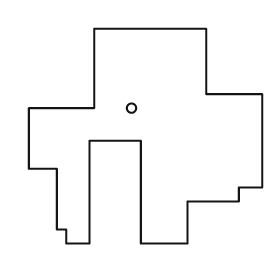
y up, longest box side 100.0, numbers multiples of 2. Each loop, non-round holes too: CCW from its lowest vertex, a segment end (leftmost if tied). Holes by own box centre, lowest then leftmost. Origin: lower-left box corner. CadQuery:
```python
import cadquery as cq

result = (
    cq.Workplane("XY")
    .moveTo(16.0, 0.0)
    .lineTo(26.0, 0.0)
    .lineTo(26.0, 44.0)
    .lineTo(48.0, 44.0)
    .lineTo(48.0, 0.0)
    .lineTo(68.0, 0.0)
    .lineTo(68.0, 18.0)
    .lineTo(90.0, 18.0)
    .lineTo(90.0, 24.0)
    .lineTo(100.0, 24.0)
    .lineTo(100.0, 64.0)
    .lineTo(76.0, 64.0)
    .lineTo(76.0, 92.0)
    .lineTo(28.0, 92.0)
    .lineTo(28.0, 58.0)
    .lineTo(0.0, 58.0)
    .lineTo(0.0, 32.0)
    .lineTo(12.0, 32.0)
    .lineTo(12.0, 6.0)
    .lineTo(16.0, 6.0)
    .close()
    .moveTo(44.0, 58.0)
    .circle(2.0)
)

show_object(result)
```